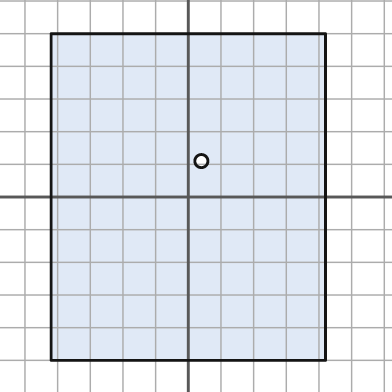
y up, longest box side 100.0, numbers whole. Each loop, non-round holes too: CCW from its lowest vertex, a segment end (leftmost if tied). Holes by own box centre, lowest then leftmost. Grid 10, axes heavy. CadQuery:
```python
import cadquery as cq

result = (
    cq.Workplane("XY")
    .moveTo(-42.0, -50.0)
    .lineTo(42.0, -50.0)
    .lineTo(42.0, 50.0)
    .lineTo(-42.0, 50.0)
    .close()
    .moveTo(4.0, 11.0)
    .circle(2.0)
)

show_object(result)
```